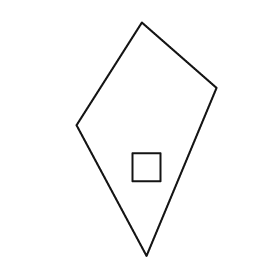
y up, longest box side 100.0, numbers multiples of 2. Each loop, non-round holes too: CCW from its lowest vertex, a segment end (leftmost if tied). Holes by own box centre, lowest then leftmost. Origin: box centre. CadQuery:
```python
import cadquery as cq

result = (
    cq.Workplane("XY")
    .moveTo(0.0, -50.0)
    .lineTo(30.0, 22.0)
    .lineTo(-2.0, 50.0)
    .lineTo(-30.0, 6.0)
    .close()
    .moveTo(-6.0, -18.0)
    .lineTo(6.0, -18.0)
    .lineTo(6.0, -6.0)
    .lineTo(-6.0, -6.0)
    .close()
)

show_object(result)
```